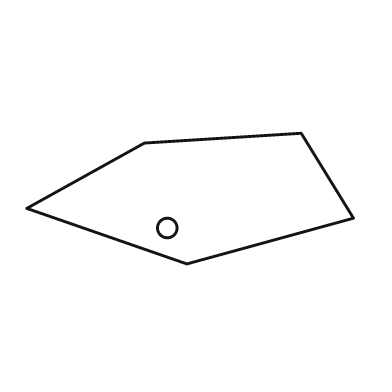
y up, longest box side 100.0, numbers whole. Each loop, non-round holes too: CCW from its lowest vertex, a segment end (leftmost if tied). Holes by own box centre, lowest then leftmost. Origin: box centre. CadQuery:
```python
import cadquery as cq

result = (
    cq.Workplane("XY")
    .moveTo(-1.0, -20.0)
    .lineTo(50.0, -6.0)
    .lineTo(34.0, 20.0)
    .lineTo(-14.0, 17.0)
    .lineTo(-50.0, -3.0)
    .close()
    .moveTo(-7.0, -9.0)
    .circle(3.0)
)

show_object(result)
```